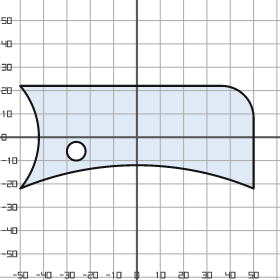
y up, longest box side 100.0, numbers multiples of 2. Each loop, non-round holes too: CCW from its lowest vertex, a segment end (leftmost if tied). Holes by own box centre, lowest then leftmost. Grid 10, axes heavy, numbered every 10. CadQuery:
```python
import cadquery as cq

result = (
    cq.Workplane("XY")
    .moveTo(-50.0, -22.0)
    .threePointArc((0.0, -12.0), (50.0, -22.0))
    .lineTo(50.0, 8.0)
    .threePointArc((46.0, 18.0), (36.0, 22.0))
    .lineTo(-50.0, 22.0)
    .threePointArc((-42.0, 0.0), (-50.0, -22.0))
    .close()
    .moveTo(-26.0, -6.0)
    .circle(4.0)
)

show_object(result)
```